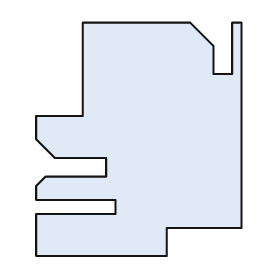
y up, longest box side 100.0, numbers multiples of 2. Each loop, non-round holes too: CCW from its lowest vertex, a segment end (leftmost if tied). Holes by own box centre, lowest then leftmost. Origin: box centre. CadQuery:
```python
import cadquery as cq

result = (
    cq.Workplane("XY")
    .moveTo(-44.0, -50.0)
    .lineTo(12.0, -50.0)
    .lineTo(12.0, -38.0)
    .lineTo(44.0, -38.0)
    .lineTo(44.0, 50.0)
    .lineTo(40.0, 50.0)
    .lineTo(40.0, 28.0)
    .lineTo(32.0, 28.0)
    .lineTo(32.0, 40.0)
    .lineTo(22.0, 50.0)
    .lineTo(-24.0, 50.0)
    .lineTo(-24.0, 10.0)
    .lineTo(-44.0, 10.0)
    .lineTo(-44.0, 0.0)
    .lineTo(-36.0, -8.0)
    .lineTo(-14.0, -8.0)
    .lineTo(-14.0, -16.0)
    .lineTo(-40.0, -16.0)
    .lineTo(-44.0, -20.0)
    .lineTo(-44.0, -26.0)
    .lineTo(-10.0, -26.0)
    .lineTo(-10.0, -32.0)
    .lineTo(-44.0, -32.0)
    .close()
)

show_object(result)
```